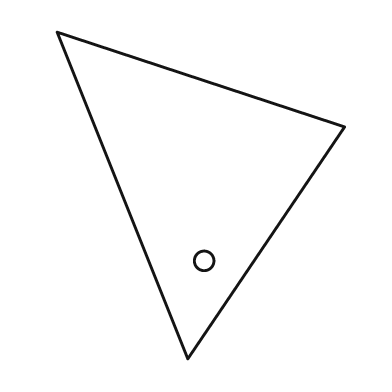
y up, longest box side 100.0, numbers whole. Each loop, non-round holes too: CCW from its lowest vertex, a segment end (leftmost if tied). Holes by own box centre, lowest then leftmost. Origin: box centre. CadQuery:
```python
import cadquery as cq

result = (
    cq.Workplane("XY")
    .moveTo(-4.0, -50.0)
    .lineTo(44.0, 21.0)
    .lineTo(-44.0, 50.0)
    .close()
    .moveTo(1.0, -20.0)
    .circle(3.0)
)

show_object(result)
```